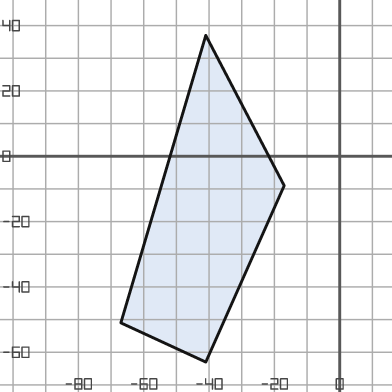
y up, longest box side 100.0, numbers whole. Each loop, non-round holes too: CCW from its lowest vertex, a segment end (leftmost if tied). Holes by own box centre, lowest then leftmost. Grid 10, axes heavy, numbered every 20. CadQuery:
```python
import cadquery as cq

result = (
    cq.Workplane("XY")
    .moveTo(-41.0, -63.0)
    .lineTo(-17.0, -9.0)
    .lineTo(-41.0, 37.0)
    .lineTo(-67.0, -51.0)
    .close()
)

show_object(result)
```